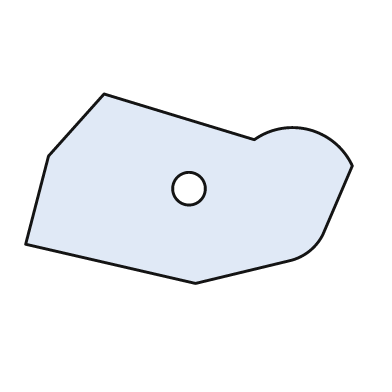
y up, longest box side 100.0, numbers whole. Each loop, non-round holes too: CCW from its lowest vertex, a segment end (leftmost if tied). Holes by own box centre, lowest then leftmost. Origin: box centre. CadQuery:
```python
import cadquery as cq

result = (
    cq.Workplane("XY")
    .moveTo(2.0, -29.0)
    .lineTo(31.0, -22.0)
    .threePointArc((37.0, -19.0), (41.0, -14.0))
    .lineTo(50.0, 7.0)
    .threePointArc((37.0, 18.0), (20.0, 15.0))
    .lineTo(-26.0, 29.0)
    .lineTo(-43.0, 10.0)
    .lineTo(-50.0, -17.0)
    .close()
    .moveTo(0.0, 0.0)
    .circle(5.0)
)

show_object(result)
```